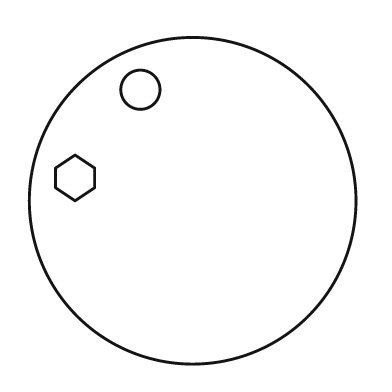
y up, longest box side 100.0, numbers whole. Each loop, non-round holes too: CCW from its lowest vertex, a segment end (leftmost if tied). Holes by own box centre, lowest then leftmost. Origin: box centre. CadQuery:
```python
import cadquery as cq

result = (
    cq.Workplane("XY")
    .moveTo(0.0, 0.0)
    .circle(50.0)
    .moveTo(-36.0, 0.0)
    .lineTo(-30.0, 4.0)
    .lineTo(-30.0, 10.0)
    .lineTo(-36.0, 14.0)
    .lineTo(-42.0, 10.0)
    .lineTo(-42.0, 4.0)
    .close()
    .moveTo(-16.0, 34.0)
    .circle(6.0)
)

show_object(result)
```